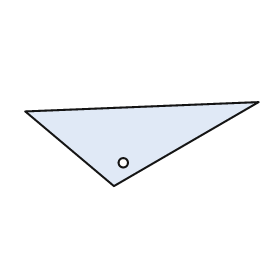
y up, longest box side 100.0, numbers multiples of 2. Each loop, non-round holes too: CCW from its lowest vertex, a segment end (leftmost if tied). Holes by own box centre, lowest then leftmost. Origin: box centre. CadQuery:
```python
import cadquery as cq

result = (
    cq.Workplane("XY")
    .moveTo(-12.0, -18.0)
    .lineTo(50.0, 18.0)
    .lineTo(-50.0, 14.0)
    .close()
    .moveTo(-8.0, -8.0)
    .circle(2.0)
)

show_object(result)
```